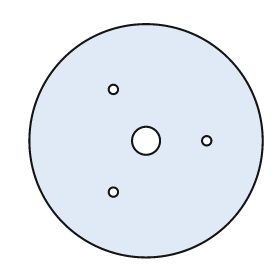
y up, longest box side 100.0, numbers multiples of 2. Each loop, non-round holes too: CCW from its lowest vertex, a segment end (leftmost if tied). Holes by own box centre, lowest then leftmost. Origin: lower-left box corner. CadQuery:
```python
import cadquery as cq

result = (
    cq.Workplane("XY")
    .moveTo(50.0, 50.0)
    .circle(50.0)
    .moveTo(36.0, 28.0)
    .circle(2.0)
    .moveTo(50.0, 50.0)
    .circle(6.0)
    .moveTo(76.0, 50.0)
    .circle(2.0)
    .moveTo(36.0, 72.0)
    .circle(2.0)
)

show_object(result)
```